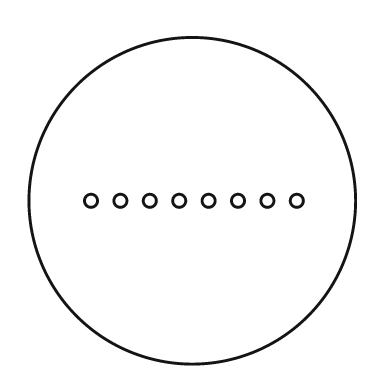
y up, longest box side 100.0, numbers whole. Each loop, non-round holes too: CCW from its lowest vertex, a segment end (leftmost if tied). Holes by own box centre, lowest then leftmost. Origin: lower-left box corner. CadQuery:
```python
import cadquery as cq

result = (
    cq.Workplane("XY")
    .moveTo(50.0, 50.0)
    .circle(50.0)
    .moveTo(19.0, 50.0)
    .circle(2.0)
    .moveTo(28.0, 50.0)
    .circle(2.0)
    .moveTo(37.0, 50.0)
    .circle(2.0)
    .moveTo(46.0, 50.0)
    .circle(2.0)
    .moveTo(55.0, 50.0)
    .circle(2.0)
    .moveTo(64.0, 50.0)
    .circle(2.0)
    .moveTo(73.0, 50.0)
    .circle(2.0)
    .moveTo(82.0, 50.0)
    .circle(2.0)
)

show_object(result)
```